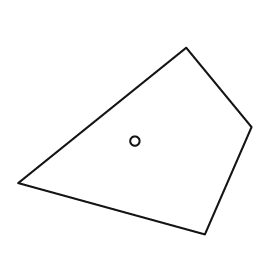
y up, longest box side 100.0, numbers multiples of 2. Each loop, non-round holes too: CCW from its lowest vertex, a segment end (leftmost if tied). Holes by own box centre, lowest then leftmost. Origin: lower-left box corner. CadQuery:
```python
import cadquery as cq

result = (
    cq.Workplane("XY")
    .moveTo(80.0, 0.0)
    .lineTo(100.0, 46.0)
    .lineTo(72.0, 80.0)
    .lineTo(0.0, 22.0)
    .close()
    .moveTo(50.0, 40.0)
    .circle(2.0)
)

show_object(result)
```